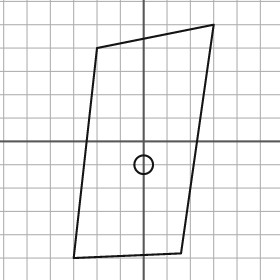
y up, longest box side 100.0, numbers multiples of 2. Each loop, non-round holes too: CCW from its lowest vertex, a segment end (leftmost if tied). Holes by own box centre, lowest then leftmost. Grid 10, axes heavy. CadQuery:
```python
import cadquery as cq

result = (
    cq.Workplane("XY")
    .moveTo(-30.0, -50.0)
    .lineTo(16.0, -48.0)
    .lineTo(30.0, 50.0)
    .lineTo(-20.0, 40.0)
    .close()
    .moveTo(0.0, -10.0)
    .circle(4.0)
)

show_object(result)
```